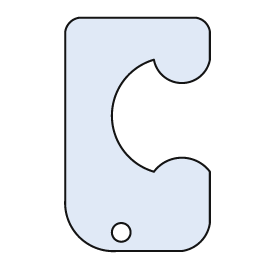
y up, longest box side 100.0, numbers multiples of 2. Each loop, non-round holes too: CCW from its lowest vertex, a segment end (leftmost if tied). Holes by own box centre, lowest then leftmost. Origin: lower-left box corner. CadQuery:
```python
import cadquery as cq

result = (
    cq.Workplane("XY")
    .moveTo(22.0, 0.0)
    .lineTo(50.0, 0.0)
    .threePointArc((58.0, 4.0), (62.0, 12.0))
    .lineTo(62.0, 34.0)
    .threePointArc((50.0, 40.0), (38.0, 34.0))
    .threePointArc((20.0, 58.0), (38.0, 82.0))
    .threePointArc((50.0, 72.0), (62.0, 82.0))
    .lineTo(62.0, 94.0)
    .threePointArc((60.0, 98.0), (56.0, 100.0))
    .lineTo(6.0, 100.0)
    .threePointArc((2.0, 98.0), (0.0, 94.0))
    .lineTo(0.0, 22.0)
    .threePointArc((6.0, 6.0), (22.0, 0.0))
    .close()
    .moveTo(24.0, 8.0)
    .circle(4.0)
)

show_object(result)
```